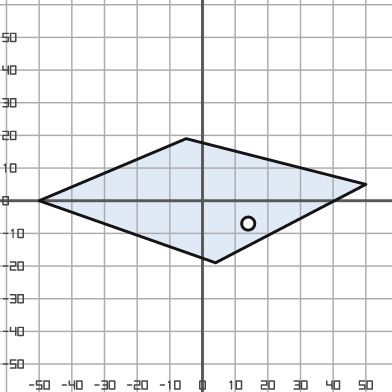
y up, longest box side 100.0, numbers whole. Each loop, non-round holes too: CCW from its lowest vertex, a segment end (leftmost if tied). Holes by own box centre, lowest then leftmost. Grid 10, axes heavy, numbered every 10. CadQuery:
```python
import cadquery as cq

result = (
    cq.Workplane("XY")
    .moveTo(4.0, -19.0)
    .lineTo(50.0, 5.0)
    .lineTo(-5.0, 19.0)
    .lineTo(-50.0, 0.0)
    .close()
    .moveTo(14.0, -7.0)
    .circle(2.0)
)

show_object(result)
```